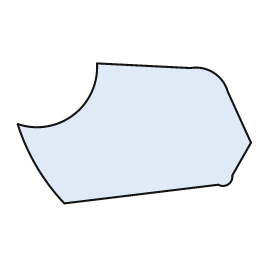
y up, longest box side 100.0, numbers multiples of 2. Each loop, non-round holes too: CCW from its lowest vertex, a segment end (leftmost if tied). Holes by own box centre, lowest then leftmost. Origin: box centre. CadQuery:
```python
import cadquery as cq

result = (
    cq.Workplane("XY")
    .moveTo(-30.0, -30.0)
    .lineTo(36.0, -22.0)
    .threePointArc((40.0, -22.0), (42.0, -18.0))
    .lineTo(50.0, -4.0)
    .lineTo(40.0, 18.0)
    .threePointArc((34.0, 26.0), (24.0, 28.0))
    .lineTo(-16.0, 30.0)
    .threePointArc((-26.0, 8.0), (-50.0, 4.0))
    .threePointArc((-42.0, -14.0), (-30.0, -30.0))
    .close()
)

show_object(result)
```